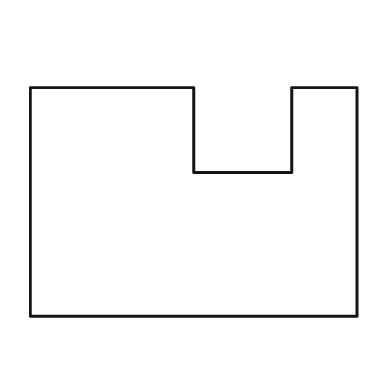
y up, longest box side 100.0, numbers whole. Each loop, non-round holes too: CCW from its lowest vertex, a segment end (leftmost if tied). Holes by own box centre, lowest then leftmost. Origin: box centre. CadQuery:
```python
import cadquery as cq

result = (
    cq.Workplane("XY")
    .moveTo(-50.0, -35.0)
    .lineTo(50.0, -35.0)
    .lineTo(50.0, 35.0)
    .lineTo(30.0, 35.0)
    .lineTo(30.0, 9.0)
    .lineTo(0.0, 9.0)
    .lineTo(0.0, 35.0)
    .lineTo(-50.0, 35.0)
    .close()
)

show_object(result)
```